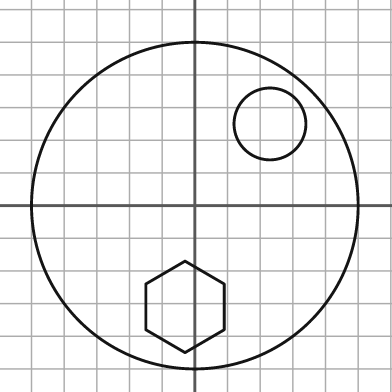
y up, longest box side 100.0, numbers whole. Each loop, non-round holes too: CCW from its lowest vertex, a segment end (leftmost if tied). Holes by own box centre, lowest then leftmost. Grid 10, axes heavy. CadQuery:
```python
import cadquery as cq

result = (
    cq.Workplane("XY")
    .moveTo(0.0, 0.0)
    .circle(50.0)
    .moveTo(-3.0, -45.0)
    .lineTo(9.0, -38.0)
    .lineTo(9.0, -24.0)
    .lineTo(-3.0, -17.0)
    .lineTo(-15.0, -24.0)
    .lineTo(-15.0, -38.0)
    .close()
    .moveTo(23.0, 25.0)
    .circle(11.0)
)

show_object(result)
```